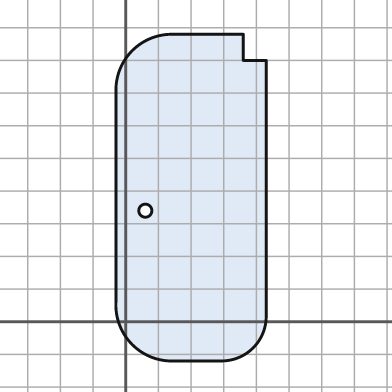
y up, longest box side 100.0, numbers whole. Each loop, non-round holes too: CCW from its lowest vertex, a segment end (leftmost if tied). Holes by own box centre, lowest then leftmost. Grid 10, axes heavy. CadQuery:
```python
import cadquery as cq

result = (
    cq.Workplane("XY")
    .moveTo(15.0, -12.0)
    .lineTo(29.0, -12.0)
    .threePointArc((39.0, -8.0), (43.0, 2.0))
    .lineTo(43.0, 80.0)
    .lineTo(36.0, 80.0)
    .lineTo(36.0, 88.0)
    .lineTo(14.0, 88.0)
    .threePointArc((2.0, 83.0), (-3.0, 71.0))
    .lineTo(-3.0, 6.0)
    .threePointArc((2.0, -7.0), (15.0, -12.0))
    .close()
    .moveTo(6.0, 34.0)
    .circle(2.0)
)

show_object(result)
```